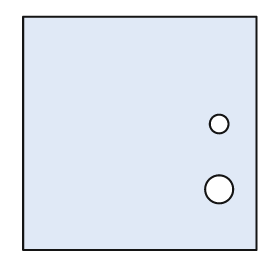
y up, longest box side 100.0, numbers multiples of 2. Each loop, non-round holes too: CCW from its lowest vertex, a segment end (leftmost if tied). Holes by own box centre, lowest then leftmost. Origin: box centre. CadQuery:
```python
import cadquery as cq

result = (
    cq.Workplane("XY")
    .moveTo(-50.0, -50.0)
    .lineTo(50.0, -50.0)
    .lineTo(50.0, 50.0)
    .lineTo(-50.0, 50.0)
    .close()
    .moveTo(34.0, -24.0)
    .circle(6.0)
    .moveTo(34.0, 4.0)
    .circle(4.0)
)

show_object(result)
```